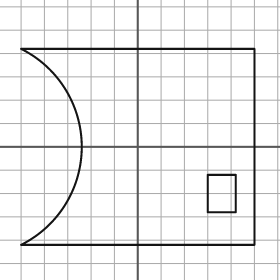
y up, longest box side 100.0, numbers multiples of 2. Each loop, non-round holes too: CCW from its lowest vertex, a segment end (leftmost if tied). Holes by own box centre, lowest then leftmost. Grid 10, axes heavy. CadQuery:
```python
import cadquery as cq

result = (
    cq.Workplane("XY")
    .moveTo(-50.0, -42.0)
    .lineTo(50.0, -42.0)
    .lineTo(50.0, 42.0)
    .lineTo(-50.0, 42.0)
    .threePointArc((-24.0, 0.0), (-50.0, -42.0))
    .close()
    .moveTo(30.0, -28.0)
    .lineTo(42.0, -28.0)
    .lineTo(42.0, -12.0)
    .lineTo(30.0, -12.0)
    .close()
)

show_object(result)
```